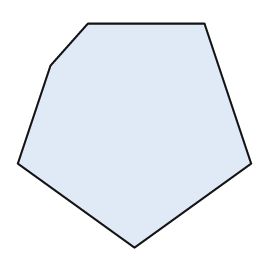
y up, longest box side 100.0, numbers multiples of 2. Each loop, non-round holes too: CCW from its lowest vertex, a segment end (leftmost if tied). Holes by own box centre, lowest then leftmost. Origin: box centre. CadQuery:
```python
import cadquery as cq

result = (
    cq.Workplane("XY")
    .moveTo(0.0, -48.0)
    .lineTo(50.0, -12.0)
    .lineTo(30.0, 48.0)
    .lineTo(-20.0, 48.0)
    .lineTo(-36.0, 30.0)
    .lineTo(-50.0, -12.0)
    .close()
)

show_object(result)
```